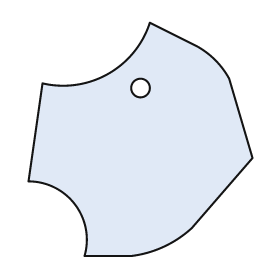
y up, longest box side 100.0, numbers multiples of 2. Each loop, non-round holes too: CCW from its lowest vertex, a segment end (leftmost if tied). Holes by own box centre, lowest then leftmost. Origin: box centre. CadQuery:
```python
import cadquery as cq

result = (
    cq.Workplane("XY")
    .moveTo(-24.0, -50.0)
    .lineTo(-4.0, -50.0)
    .threePointArc((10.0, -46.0), (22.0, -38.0))
    .lineTo(48.0, -8.0)
    .lineTo(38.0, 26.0)
    .threePointArc((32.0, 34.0), (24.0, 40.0))
    .lineTo(4.0, 50.0)
    .threePointArc((-14.0, 28.0), (-42.0, 24.0))
    .lineTo(-48.0, -18.0)
    .threePointArc((-28.0, -28.0), (-24.0, -50.0))
    .close()
    .moveTo(0.0, 22.0)
    .circle(4.0)
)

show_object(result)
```